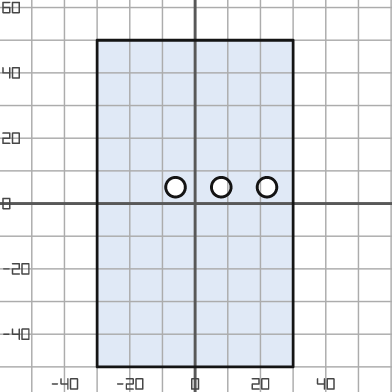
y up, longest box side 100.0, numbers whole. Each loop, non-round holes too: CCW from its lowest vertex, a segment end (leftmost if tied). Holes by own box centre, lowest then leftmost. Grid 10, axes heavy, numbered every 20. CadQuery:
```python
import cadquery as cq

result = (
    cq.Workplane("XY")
    .moveTo(-30.0, -50.0)
    .lineTo(30.0, -50.0)
    .lineTo(30.0, 50.0)
    .lineTo(-30.0, 50.0)
    .close()
    .moveTo(-6.0, 5.0)
    .circle(3.0)
    .moveTo(8.0, 5.0)
    .circle(3.0)
    .moveTo(22.0, 5.0)
    .circle(3.0)
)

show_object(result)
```